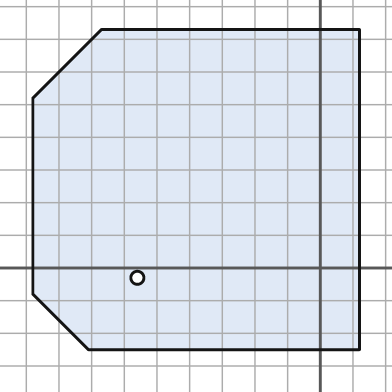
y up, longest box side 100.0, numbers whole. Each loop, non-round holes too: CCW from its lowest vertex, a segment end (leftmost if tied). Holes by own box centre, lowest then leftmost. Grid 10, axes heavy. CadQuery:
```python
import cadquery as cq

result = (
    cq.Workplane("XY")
    .moveTo(-71.0, -25.0)
    .lineTo(12.0, -25.0)
    .lineTo(12.0, 73.0)
    .lineTo(-67.0, 73.0)
    .lineTo(-88.0, 52.0)
    .lineTo(-88.0, -8.0)
    .close()
    .moveTo(-56.0, -3.0)
    .circle(2.0)
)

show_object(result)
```